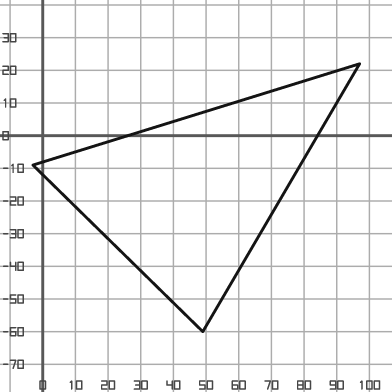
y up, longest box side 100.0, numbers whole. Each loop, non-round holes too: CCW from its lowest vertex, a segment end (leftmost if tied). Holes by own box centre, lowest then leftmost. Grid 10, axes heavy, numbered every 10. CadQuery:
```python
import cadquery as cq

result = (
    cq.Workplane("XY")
    .moveTo(49.0, -60.0)
    .lineTo(97.0, 22.0)
    .lineTo(-3.0, -9.0)
    .close()
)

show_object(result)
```